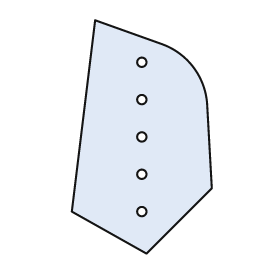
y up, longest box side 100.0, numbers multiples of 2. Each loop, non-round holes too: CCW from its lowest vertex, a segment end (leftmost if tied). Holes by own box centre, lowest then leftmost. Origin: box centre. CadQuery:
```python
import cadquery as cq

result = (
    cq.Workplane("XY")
    .moveTo(2.0, -50.0)
    .lineTo(30.0, -22.0)
    .lineTo(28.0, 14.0)
    .threePointArc((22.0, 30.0), (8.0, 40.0))
    .lineTo(-20.0, 50.0)
    .lineTo(-30.0, -32.0)
    .close()
    .moveTo(0.0, -32.0)
    .circle(2.0)
    .moveTo(0.0, -16.0)
    .circle(2.0)
    .moveTo(0.0, 0.0)
    .circle(2.0)
    .moveTo(0.0, 16.0)
    .circle(2.0)
    .moveTo(0.0, 32.0)
    .circle(2.0)
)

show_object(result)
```